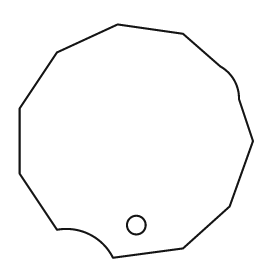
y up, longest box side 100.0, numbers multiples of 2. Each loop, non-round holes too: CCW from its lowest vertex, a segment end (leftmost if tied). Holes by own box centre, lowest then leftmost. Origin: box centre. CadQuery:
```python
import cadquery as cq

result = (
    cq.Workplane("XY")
    .moveTo(-10.0, -50.0)
    .lineTo(20.0, -46.0)
    .lineTo(40.0, -28.0)
    .lineTo(50.0, 0.0)
    .lineTo(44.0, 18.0)
    .threePointArc((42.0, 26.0), (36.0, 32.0))
    .lineTo(20.0, 46.0)
    .lineTo(-8.0, 50.0)
    .lineTo(-34.0, 38.0)
    .lineTo(-50.0, 14.0)
    .lineTo(-50.0, -14.0)
    .lineTo(-34.0, -38.0)
    .threePointArc((-20.0, -40.0), (-10.0, -50.0))
    .close()
    .moveTo(0.0, -36.0)
    .circle(4.0)
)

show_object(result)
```